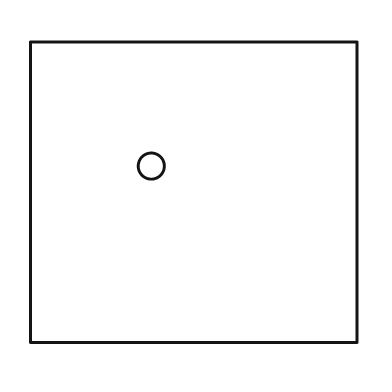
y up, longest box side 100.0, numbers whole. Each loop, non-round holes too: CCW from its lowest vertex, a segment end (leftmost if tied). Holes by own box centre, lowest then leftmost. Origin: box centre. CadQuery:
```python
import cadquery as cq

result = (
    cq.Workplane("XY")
    .moveTo(-50.0, -46.0)
    .lineTo(50.0, -46.0)
    .lineTo(50.0, 46.0)
    .lineTo(-50.0, 46.0)
    .close()
    .moveTo(-13.0, 8.0)
    .circle(4.0)
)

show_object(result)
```